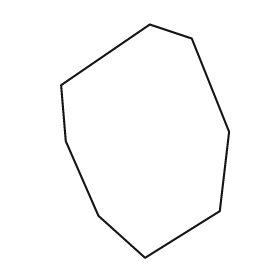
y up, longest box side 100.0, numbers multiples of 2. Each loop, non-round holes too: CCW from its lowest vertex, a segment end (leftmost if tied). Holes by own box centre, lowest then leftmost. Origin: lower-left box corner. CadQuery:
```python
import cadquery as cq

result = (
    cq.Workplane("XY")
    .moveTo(36.0, 0.0)
    .lineTo(68.0, 20.0)
    .lineTo(72.0, 54.0)
    .lineTo(56.0, 94.0)
    .lineTo(38.0, 100.0)
    .lineTo(0.0, 74.0)
    .lineTo(2.0, 50.0)
    .lineTo(16.0, 18.0)
    .close()
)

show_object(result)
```